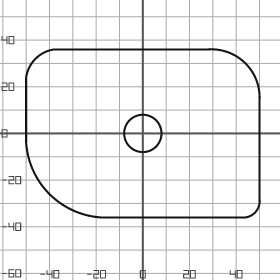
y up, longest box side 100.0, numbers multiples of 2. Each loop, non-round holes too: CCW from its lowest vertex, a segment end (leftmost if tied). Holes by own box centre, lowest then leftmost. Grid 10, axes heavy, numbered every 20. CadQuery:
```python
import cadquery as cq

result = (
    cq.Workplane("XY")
    .moveTo(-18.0, -36.0)
    .lineTo(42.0, -36.0)
    .threePointArc((48.0, -34.0), (50.0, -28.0))
    .lineTo(50.0, 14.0)
    .threePointArc((44.0, 30.0), (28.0, 36.0))
    .lineTo(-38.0, 36.0)
    .threePointArc((-46.0, 32.0), (-50.0, 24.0))
    .lineTo(-50.0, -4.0)
    .threePointArc((-40.0, -26.0), (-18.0, -36.0))
    .close()
    .moveTo(0.0, 0.0)
    .circle(8.0)
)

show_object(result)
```